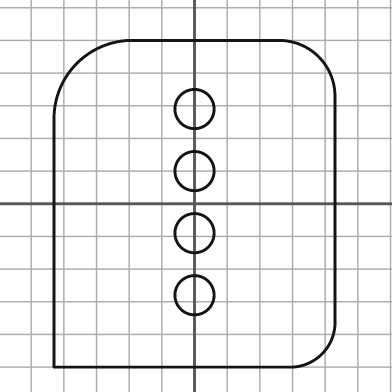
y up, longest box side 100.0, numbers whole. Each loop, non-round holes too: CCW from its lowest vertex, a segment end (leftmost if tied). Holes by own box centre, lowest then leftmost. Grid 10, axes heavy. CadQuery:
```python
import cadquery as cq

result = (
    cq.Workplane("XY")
    .moveTo(-43.0, -50.0)
    .lineTo(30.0, -50.0)
    .threePointArc((39.0, -46.0), (43.0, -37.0))
    .lineTo(43.0, 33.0)
    .threePointArc((38.0, 45.0), (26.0, 50.0))
    .lineTo(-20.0, 50.0)
    .threePointArc((-36.0, 43.0), (-43.0, 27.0))
    .close()
    .moveTo(0.0, -28.0)
    .circle(6.0)
    .moveTo(0.0, -9.0)
    .circle(6.0)
    .moveTo(0.0, 10.0)
    .circle(6.0)
    .moveTo(0.0, 29.0)
    .circle(6.0)
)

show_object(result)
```